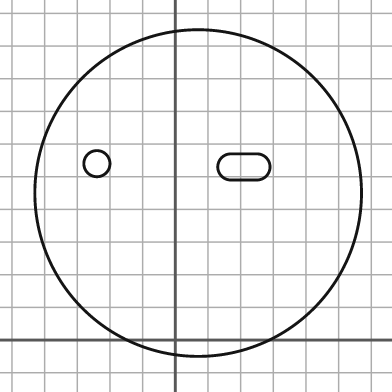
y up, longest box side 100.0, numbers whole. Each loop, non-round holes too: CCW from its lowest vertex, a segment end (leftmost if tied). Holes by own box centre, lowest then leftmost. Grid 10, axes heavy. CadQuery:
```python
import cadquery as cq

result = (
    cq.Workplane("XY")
    .moveTo(7.0, 45.0)
    .circle(50.0)
    .moveTo(17.0, 49.0)
    .lineTo(25.0, 49.0)
    .threePointArc((29.0, 53.0), (25.0, 57.0))
    .lineTo(17.0, 57.0)
    .threePointArc((13.0, 53.0), (17.0, 49.0))
    .close()
    .moveTo(-24.0, 54.0)
    .circle(4.0)
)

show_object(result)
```